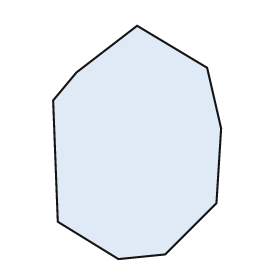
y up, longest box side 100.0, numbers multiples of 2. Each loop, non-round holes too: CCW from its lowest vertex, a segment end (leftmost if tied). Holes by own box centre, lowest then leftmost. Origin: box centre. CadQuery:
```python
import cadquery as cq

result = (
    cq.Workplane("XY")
    .moveTo(-8.0, -50.0)
    .lineTo(12.0, -48.0)
    .lineTo(34.0, -26.0)
    .lineTo(36.0, 6.0)
    .lineTo(30.0, 32.0)
    .lineTo(0.0, 50.0)
    .lineTo(-26.0, 30.0)
    .lineTo(-36.0, 18.0)
    .lineTo(-34.0, -34.0)
    .close()
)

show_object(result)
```